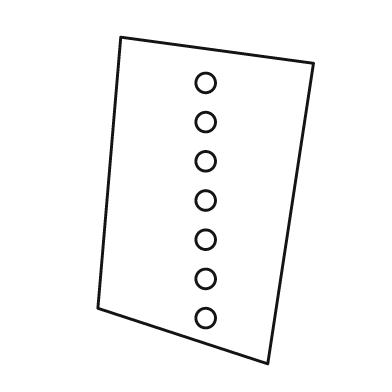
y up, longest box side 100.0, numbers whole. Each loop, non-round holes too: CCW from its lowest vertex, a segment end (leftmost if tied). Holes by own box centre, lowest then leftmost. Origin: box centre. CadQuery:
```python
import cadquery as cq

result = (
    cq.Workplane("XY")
    .moveTo(19.0, -50.0)
    .lineTo(33.0, 42.0)
    .lineTo(-26.0, 50.0)
    .lineTo(-33.0, -33.0)
    .close()
    .moveTo(0.0, -36.0)
    .circle(3.0)
    .moveTo(0.0, -24.0)
    .circle(3.0)
    .moveTo(0.0, -12.0)
    .circle(3.0)
    .moveTo(0.0, 0.0)
    .circle(3.0)
    .moveTo(0.0, 12.0)
    .circle(3.0)
    .moveTo(0.0, 24.0)
    .circle(3.0)
    .moveTo(0.0, 36.0)
    .circle(3.0)
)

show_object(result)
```